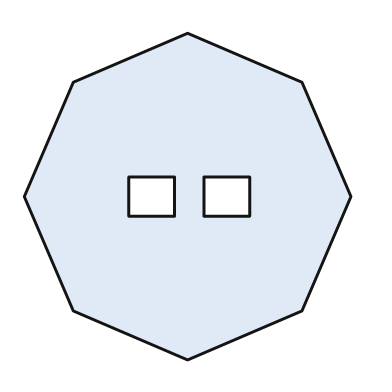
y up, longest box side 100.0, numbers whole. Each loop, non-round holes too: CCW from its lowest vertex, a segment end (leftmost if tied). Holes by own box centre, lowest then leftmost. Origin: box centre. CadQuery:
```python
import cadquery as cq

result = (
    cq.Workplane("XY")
    .moveTo(0.0, -50.0)
    .lineTo(35.0, -35.0)
    .lineTo(50.0, 0.0)
    .lineTo(35.0, 35.0)
    .lineTo(0.0, 50.0)
    .lineTo(-35.0, 35.0)
    .lineTo(-50.0, 0.0)
    .lineTo(-35.0, -35.0)
    .close()
    .moveTo(-18.0, -6.0)
    .lineTo(-4.0, -6.0)
    .lineTo(-4.0, 6.0)
    .lineTo(-18.0, 6.0)
    .close()
    .moveTo(5.0, -6.0)
    .lineTo(19.0, -6.0)
    .lineTo(19.0, 6.0)
    .lineTo(5.0, 6.0)
    .close()
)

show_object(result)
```